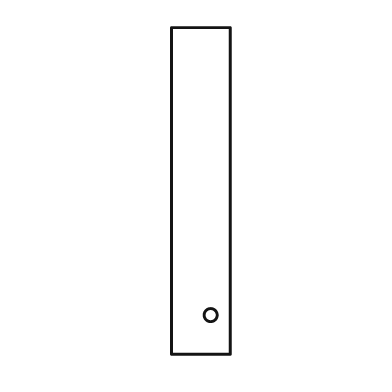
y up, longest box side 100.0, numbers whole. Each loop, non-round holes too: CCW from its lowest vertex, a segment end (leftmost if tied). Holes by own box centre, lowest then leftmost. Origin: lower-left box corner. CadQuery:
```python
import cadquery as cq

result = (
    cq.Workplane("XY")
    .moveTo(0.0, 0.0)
    .lineTo(18.0, 0.0)
    .lineTo(18.0, 100.0)
    .lineTo(0.0, 100.0)
    .close()
    .moveTo(12.0, 12.0)
    .circle(2.0)
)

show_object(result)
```